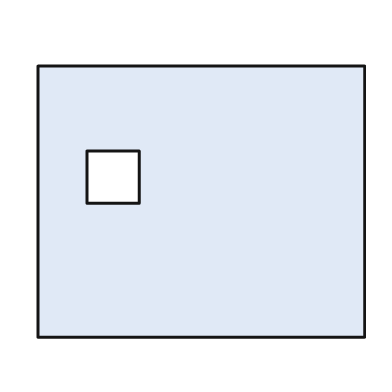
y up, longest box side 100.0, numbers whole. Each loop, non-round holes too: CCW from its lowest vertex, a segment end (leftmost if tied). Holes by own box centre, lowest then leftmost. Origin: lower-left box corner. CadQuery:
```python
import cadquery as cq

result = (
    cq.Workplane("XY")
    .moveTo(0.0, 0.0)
    .lineTo(100.0, 0.0)
    .lineTo(100.0, 83.0)
    .lineTo(0.0, 83.0)
    .close()
    .moveTo(15.0, 41.0)
    .lineTo(31.0, 41.0)
    .lineTo(31.0, 57.0)
    .lineTo(15.0, 57.0)
    .close()
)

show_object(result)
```